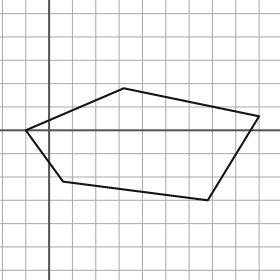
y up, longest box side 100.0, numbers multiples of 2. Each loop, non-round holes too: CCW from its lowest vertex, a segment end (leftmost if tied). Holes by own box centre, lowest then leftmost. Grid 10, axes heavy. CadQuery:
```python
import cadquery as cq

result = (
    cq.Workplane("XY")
    .moveTo(68.0, -30.0)
    .lineTo(90.0, 6.0)
    .lineTo(32.0, 18.0)
    .lineTo(-10.0, 0.0)
    .lineTo(6.0, -22.0)
    .close()
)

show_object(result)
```